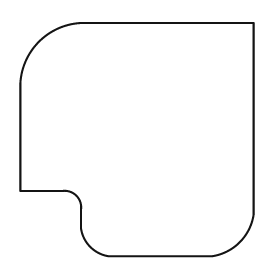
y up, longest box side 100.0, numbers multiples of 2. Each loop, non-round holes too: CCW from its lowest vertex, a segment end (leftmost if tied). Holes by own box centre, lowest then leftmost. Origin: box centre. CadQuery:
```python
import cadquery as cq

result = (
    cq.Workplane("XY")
    .moveTo(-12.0, -50.0)
    .lineTo(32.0, -50.0)
    .threePointArc((44.0, -44.0), (50.0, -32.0))
    .lineTo(50.0, 50.0)
    .lineTo(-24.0, 50.0)
    .threePointArc((-42.0, 42.0), (-50.0, 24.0))
    .lineTo(-50.0, -22.0)
    .lineTo(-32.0, -22.0)
    .threePointArc((-26.0, -24.0), (-24.0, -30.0))
    .lineTo(-24.0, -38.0)
    .threePointArc((-20.0, -46.0), (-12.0, -50.0))
    .close()
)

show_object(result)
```